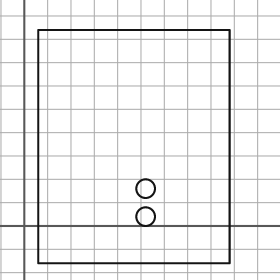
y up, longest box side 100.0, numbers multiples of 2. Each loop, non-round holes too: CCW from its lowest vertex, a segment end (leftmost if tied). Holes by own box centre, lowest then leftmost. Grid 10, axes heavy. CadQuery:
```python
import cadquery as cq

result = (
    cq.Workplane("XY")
    .moveTo(6.0, -16.0)
    .lineTo(88.0, -16.0)
    .lineTo(88.0, 84.0)
    .lineTo(6.0, 84.0)
    .close()
    .moveTo(52.0, 4.0)
    .circle(4.0)
    .moveTo(52.0, 16.0)
    .circle(4.0)
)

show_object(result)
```